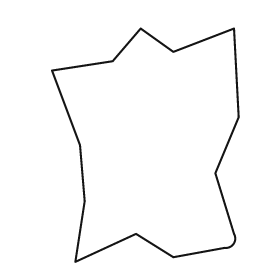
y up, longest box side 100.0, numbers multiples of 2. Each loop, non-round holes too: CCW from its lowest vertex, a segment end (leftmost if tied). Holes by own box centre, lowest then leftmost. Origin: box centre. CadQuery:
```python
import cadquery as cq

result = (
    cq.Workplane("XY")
    .moveTo(-30.0, -50.0)
    .lineTo(-4.0, -38.0)
    .lineTo(12.0, -48.0)
    .lineTo(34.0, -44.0)
    .threePointArc((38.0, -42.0), (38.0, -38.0))
    .lineTo(30.0, -12.0)
    .lineTo(40.0, 12.0)
    .lineTo(38.0, 50.0)
    .lineTo(12.0, 40.0)
    .lineTo(-2.0, 50.0)
    .lineTo(-14.0, 36.0)
    .lineTo(-40.0, 32.0)
    .lineTo(-28.0, 0.0)
    .lineTo(-26.0, -24.0)
    .close()
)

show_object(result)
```